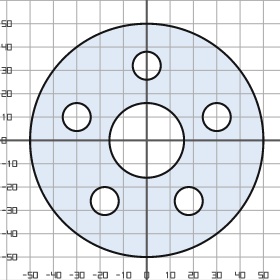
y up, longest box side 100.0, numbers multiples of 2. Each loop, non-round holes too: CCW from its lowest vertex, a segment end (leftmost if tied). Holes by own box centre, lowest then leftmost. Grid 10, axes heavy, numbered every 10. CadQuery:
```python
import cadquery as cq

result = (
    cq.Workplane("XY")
    .moveTo(0.0, 0.0)
    .circle(50.0)
    .moveTo(-18.0, -26.0)
    .circle(6.0)
    .moveTo(18.0, -26.0)
    .circle(6.0)
    .moveTo(0.0, 0.0)
    .circle(16.0)
    .moveTo(-30.0, 10.0)
    .circle(6.0)
    .moveTo(30.0, 10.0)
    .circle(6.0)
    .moveTo(0.0, 32.0)
    .circle(6.0)
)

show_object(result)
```